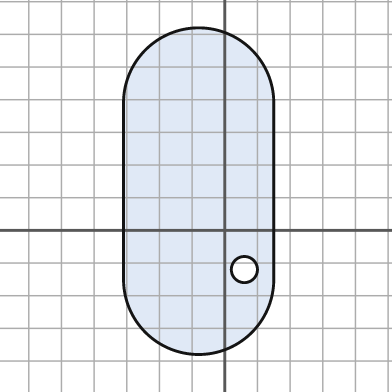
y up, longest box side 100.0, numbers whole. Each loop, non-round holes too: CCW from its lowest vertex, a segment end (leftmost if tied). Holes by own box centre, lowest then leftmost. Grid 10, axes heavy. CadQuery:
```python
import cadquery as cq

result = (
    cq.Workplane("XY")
    .moveTo(-31.0, -15.0)
    .threePointArc((-8.0, -38.0), (15.0, -15.0))
    .lineTo(15.0, 39.0)
    .threePointArc((-8.0, 62.0), (-31.0, 39.0))
    .close()
    .moveTo(6.0, -12.0)
    .circle(4.0)
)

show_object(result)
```